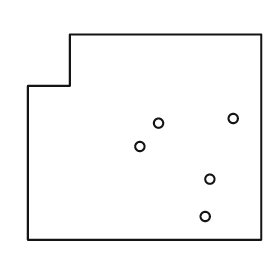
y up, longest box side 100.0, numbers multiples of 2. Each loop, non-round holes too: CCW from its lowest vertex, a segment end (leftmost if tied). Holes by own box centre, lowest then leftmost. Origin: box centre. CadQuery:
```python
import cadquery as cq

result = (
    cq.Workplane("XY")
    .moveTo(-50.0, -44.0)
    .lineTo(50.0, -44.0)
    .lineTo(50.0, 44.0)
    .lineTo(-32.0, 44.0)
    .lineTo(-32.0, 22.0)
    .lineTo(-50.0, 22.0)
    .close()
    .moveTo(26.0, -34.0)
    .circle(2.0)
    .moveTo(28.0, -18.0)
    .circle(2.0)
    .moveTo(-2.0, -4.0)
    .circle(2.0)
    .moveTo(6.0, 6.0)
    .circle(2.0)
    .moveTo(38.0, 8.0)
    .circle(2.0)
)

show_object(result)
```